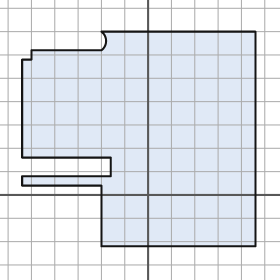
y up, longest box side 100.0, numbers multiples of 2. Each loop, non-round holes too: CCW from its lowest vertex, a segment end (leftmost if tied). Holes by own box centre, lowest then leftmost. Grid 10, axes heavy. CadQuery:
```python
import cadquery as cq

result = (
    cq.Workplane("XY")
    .moveTo(-20.0, -22.0)
    .lineTo(46.0, -22.0)
    .lineTo(46.0, 70.0)
    .lineTo(-20.0, 70.0)
    .threePointArc((-18.0, 66.0), (-20.0, 62.0))
    .lineTo(-50.0, 62.0)
    .lineTo(-50.0, 58.0)
    .lineTo(-54.0, 58.0)
    .lineTo(-54.0, 16.0)
    .lineTo(-16.0, 16.0)
    .lineTo(-16.0, 8.0)
    .lineTo(-54.0, 8.0)
    .lineTo(-54.0, 4.0)
    .lineTo(-20.0, 4.0)
    .close()
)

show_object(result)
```